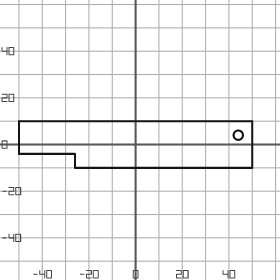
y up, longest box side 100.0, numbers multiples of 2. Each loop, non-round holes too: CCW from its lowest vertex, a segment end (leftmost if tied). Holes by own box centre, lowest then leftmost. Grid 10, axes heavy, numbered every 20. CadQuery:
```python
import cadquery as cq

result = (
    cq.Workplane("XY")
    .moveTo(-26.0, -10.0)
    .lineTo(50.0, -10.0)
    .lineTo(50.0, 10.0)
    .lineTo(-50.0, 10.0)
    .lineTo(-50.0, -4.0)
    .lineTo(-26.0, -4.0)
    .close()
    .moveTo(44.0, 4.0)
    .circle(2.0)
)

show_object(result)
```